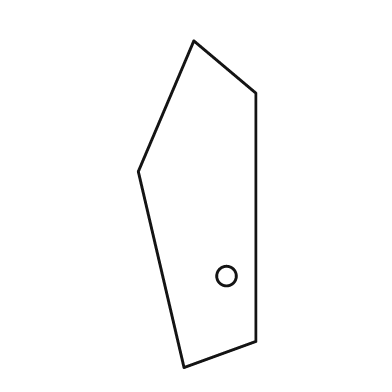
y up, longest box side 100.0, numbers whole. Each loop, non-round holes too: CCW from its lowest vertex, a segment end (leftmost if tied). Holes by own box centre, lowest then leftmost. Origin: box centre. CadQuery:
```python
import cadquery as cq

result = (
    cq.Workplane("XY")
    .moveTo(-4.0, -50.0)
    .lineTo(18.0, -42.0)
    .lineTo(18.0, 34.0)
    .lineTo(-1.0, 50.0)
    .lineTo(-18.0, 10.0)
    .close()
    .moveTo(9.0, -22.0)
    .circle(3.0)
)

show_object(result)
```